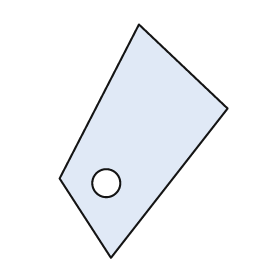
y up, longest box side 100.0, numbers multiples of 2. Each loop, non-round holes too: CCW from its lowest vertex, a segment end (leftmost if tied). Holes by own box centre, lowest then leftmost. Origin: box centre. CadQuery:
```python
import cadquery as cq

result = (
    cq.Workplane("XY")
    .moveTo(-14.0, -50.0)
    .lineTo(36.0, 14.0)
    .lineTo(-2.0, 50.0)
    .lineTo(-36.0, -16.0)
    .close()
    .moveTo(-16.0, -18.0)
    .circle(6.0)
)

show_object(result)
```